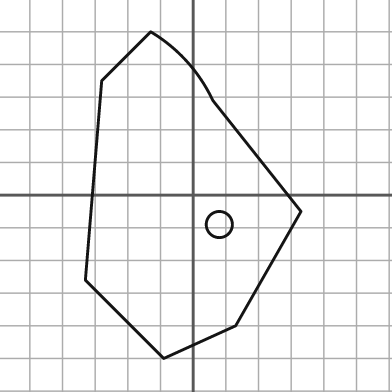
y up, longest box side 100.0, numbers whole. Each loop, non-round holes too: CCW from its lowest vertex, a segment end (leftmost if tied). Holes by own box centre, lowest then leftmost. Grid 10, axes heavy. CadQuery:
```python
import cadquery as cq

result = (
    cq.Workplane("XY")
    .moveTo(-9.0, -50.0)
    .lineTo(13.0, -40.0)
    .lineTo(33.0, -5.0)
    .lineTo(6.0, 29.0)
    .threePointArc((-2.0, 41.0), (-13.0, 50.0))
    .lineTo(-28.0, 35.0)
    .lineTo(-33.0, -26.0)
    .close()
    .moveTo(8.0, -9.0)
    .circle(4.0)
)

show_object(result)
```